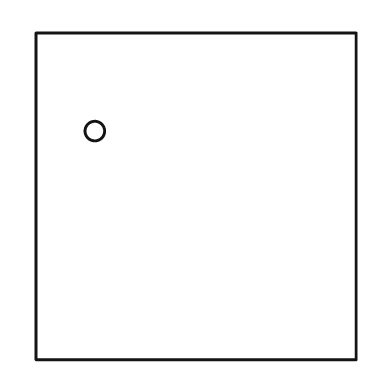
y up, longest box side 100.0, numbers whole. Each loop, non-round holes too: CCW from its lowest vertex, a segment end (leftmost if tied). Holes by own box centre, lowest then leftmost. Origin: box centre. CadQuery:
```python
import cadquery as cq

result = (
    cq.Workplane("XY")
    .moveTo(-49.0, -50.0)
    .lineTo(49.0, -50.0)
    .lineTo(49.0, 50.0)
    .lineTo(-49.0, 50.0)
    .close()
    .moveTo(-31.0, 20.0)
    .circle(3.0)
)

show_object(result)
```